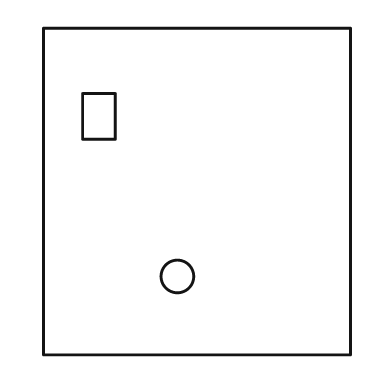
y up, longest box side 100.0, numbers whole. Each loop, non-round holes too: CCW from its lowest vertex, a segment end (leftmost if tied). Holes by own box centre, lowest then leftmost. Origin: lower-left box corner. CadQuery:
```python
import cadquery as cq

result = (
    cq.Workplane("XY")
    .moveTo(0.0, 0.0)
    .lineTo(94.0, 0.0)
    .lineTo(94.0, 100.0)
    .lineTo(0.0, 100.0)
    .close()
    .moveTo(41.0, 24.0)
    .circle(5.0)
    .moveTo(12.0, 66.0)
    .lineTo(22.0, 66.0)
    .lineTo(22.0, 80.0)
    .lineTo(12.0, 80.0)
    .close()
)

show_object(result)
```